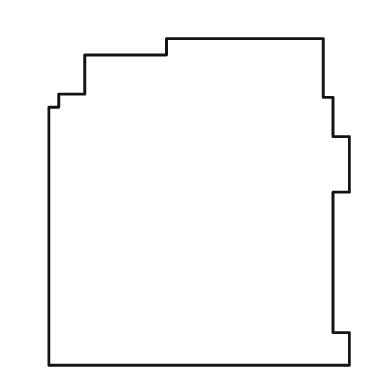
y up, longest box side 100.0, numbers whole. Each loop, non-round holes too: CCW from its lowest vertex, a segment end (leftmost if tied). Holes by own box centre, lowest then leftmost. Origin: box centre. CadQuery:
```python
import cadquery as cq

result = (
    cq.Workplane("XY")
    .moveTo(-46.0, -50.0)
    .lineTo(46.0, -50.0)
    .lineTo(46.0, -40.0)
    .lineTo(41.0, -40.0)
    .lineTo(41.0, 3.0)
    .lineTo(46.0, 3.0)
    .lineTo(46.0, 20.0)
    .lineTo(41.0, 20.0)
    .lineTo(41.0, 32.0)
    .lineTo(38.0, 32.0)
    .lineTo(38.0, 50.0)
    .lineTo(-10.0, 50.0)
    .lineTo(-10.0, 45.0)
    .lineTo(-35.0, 45.0)
    .lineTo(-35.0, 33.0)
    .lineTo(-43.0, 33.0)
    .lineTo(-43.0, 29.0)
    .lineTo(-46.0, 29.0)
    .close()
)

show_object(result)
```